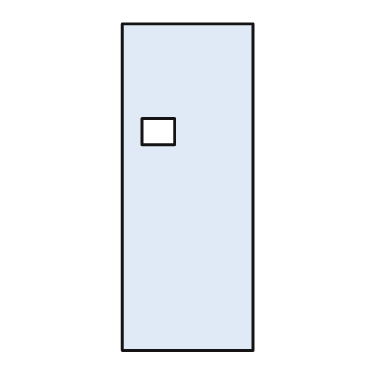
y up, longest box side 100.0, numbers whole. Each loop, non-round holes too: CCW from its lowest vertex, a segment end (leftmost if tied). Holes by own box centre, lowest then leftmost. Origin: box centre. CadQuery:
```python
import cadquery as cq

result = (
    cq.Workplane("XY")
    .moveTo(-20.0, -50.0)
    .lineTo(20.0, -50.0)
    .lineTo(20.0, 50.0)
    .lineTo(-20.0, 50.0)
    .close()
    .moveTo(-14.0, 13.0)
    .lineTo(-4.0, 13.0)
    .lineTo(-4.0, 21.0)
    .lineTo(-14.0, 21.0)
    .close()
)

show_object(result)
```